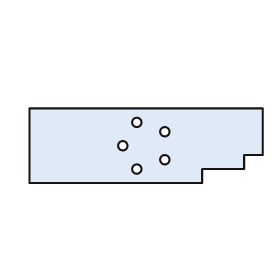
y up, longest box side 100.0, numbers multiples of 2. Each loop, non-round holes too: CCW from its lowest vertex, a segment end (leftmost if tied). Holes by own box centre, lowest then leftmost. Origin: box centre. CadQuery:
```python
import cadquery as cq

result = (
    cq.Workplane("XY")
    .moveTo(-50.0, -16.0)
    .lineTo(24.0, -16.0)
    .lineTo(24.0, -10.0)
    .lineTo(42.0, -10.0)
    .lineTo(42.0, -4.0)
    .lineTo(50.0, -4.0)
    .lineTo(50.0, 16.0)
    .lineTo(-50.0, 16.0)
    .close()
    .moveTo(-4.0, -10.0)
    .circle(2.0)
    .moveTo(8.0, -6.0)
    .circle(2.0)
    .moveTo(-10.0, 0.0)
    .circle(2.0)
    .moveTo(8.0, 6.0)
    .circle(2.0)
    .moveTo(-4.0, 10.0)
    .circle(2.0)
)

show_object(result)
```